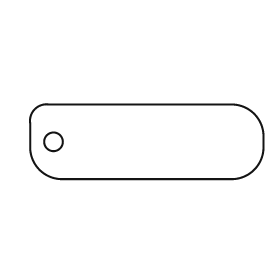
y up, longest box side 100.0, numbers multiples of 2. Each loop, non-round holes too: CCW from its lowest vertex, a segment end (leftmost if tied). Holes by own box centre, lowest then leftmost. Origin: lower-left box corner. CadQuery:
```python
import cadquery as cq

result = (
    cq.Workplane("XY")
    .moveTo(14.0, 0.0)
    .lineTo(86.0, 0.0)
    .threePointArc((96.0, 4.0), (100.0, 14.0))
    .lineTo(100.0, 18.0)
    .threePointArc((96.0, 28.0), (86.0, 32.0))
    .lineTo(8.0, 32.0)
    .threePointArc((2.0, 30.0), (0.0, 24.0))
    .lineTo(0.0, 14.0)
    .threePointArc((4.0, 4.0), (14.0, 0.0))
    .close()
    .moveTo(10.0, 16.0)
    .circle(4.0)
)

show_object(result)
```